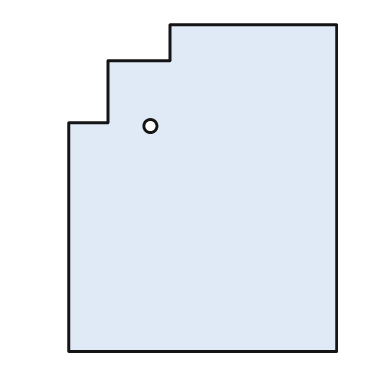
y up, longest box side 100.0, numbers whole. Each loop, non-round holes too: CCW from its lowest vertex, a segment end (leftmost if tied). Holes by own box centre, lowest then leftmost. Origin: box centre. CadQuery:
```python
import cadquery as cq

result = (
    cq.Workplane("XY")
    .moveTo(-41.0, -50.0)
    .lineTo(41.0, -50.0)
    .lineTo(41.0, 50.0)
    .lineTo(-10.0, 50.0)
    .lineTo(-10.0, 39.0)
    .lineTo(-29.0, 39.0)
    .lineTo(-29.0, 20.0)
    .lineTo(-41.0, 20.0)
    .close()
    .moveTo(-16.0, 19.0)
    .circle(2.0)
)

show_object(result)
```